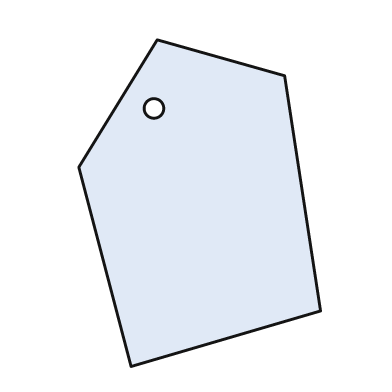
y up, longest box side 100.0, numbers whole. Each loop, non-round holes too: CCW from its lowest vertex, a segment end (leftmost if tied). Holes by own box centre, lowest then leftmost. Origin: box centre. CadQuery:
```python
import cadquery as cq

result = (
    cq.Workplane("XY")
    .moveTo(-21.0, -50.0)
    .lineTo(37.0, -33.0)
    .lineTo(26.0, 39.0)
    .lineTo(-13.0, 50.0)
    .lineTo(-37.0, 11.0)
    .close()
    .moveTo(-14.0, 29.0)
    .circle(3.0)
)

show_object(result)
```